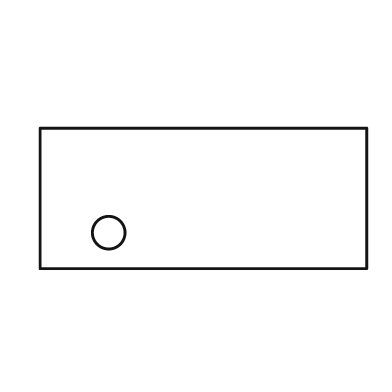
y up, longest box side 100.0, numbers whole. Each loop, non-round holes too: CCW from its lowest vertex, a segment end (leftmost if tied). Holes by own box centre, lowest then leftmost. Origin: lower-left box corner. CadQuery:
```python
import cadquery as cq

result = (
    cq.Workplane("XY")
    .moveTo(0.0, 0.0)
    .lineTo(100.0, 0.0)
    .lineTo(100.0, 43.0)
    .lineTo(0.0, 43.0)
    .close()
    .moveTo(21.0, 11.0)
    .circle(5.0)
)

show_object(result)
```